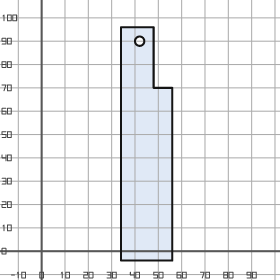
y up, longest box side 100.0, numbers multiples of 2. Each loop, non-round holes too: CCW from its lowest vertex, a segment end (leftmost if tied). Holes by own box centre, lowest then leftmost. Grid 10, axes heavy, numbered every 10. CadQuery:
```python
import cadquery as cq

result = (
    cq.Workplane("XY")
    .moveTo(34.0, -4.0)
    .lineTo(56.0, -4.0)
    .lineTo(56.0, 70.0)
    .lineTo(48.0, 70.0)
    .lineTo(48.0, 96.0)
    .lineTo(34.0, 96.0)
    .close()
    .moveTo(42.0, 90.0)
    .circle(2.0)
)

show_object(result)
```